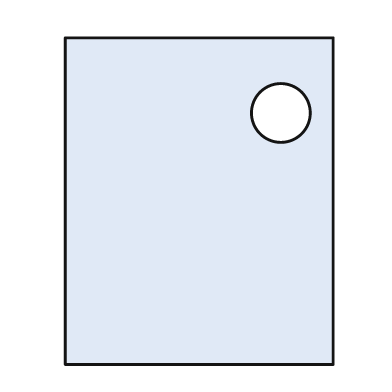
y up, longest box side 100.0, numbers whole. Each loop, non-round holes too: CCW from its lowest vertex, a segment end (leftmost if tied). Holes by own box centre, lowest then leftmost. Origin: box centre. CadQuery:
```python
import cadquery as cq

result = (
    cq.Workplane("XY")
    .moveTo(-41.0, -50.0)
    .lineTo(41.0, -50.0)
    .lineTo(41.0, 50.0)
    .lineTo(-41.0, 50.0)
    .close()
    .moveTo(25.0, 27.0)
    .circle(9.0)
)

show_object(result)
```